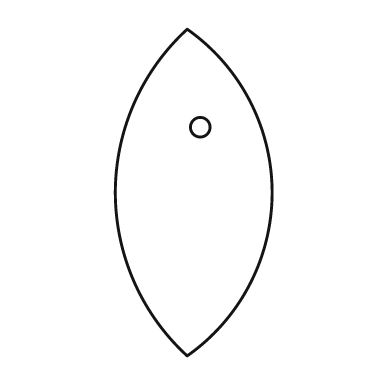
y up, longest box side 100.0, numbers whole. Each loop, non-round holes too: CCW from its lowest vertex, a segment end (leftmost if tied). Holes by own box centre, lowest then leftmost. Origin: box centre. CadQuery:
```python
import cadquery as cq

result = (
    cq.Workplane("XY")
    .moveTo(-2.0, -50.0)
    .threePointArc((24.0, 0.0), (-2.0, 50.0))
    .threePointArc((-24.0, 0.0), (-2.0, -50.0))
    .close()
    .moveTo(2.0, 20.0)
    .circle(3.0)
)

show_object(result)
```